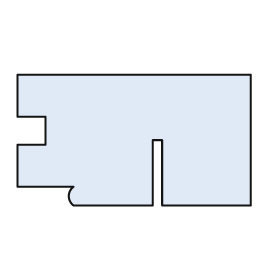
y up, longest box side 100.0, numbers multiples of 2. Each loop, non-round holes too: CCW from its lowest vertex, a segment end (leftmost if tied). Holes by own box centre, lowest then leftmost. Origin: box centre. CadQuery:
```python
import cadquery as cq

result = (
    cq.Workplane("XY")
    .moveTo(-26.0, -28.0)
    .lineTo(8.0, -28.0)
    .lineTo(8.0, 0.0)
    .lineTo(12.0, 0.0)
    .lineTo(12.0, -28.0)
    .lineTo(50.0, -28.0)
    .lineTo(50.0, 28.0)
    .lineTo(-50.0, 28.0)
    .lineTo(-50.0, 10.0)
    .lineTo(-38.0, 10.0)
    .lineTo(-38.0, -2.0)
    .lineTo(-50.0, -2.0)
    .lineTo(-50.0, -20.0)
    .lineTo(-26.0, -20.0)
    .threePointArc((-28.0, -24.0), (-26.0, -28.0))
    .close()
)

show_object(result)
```